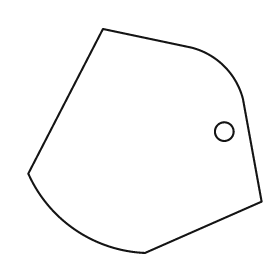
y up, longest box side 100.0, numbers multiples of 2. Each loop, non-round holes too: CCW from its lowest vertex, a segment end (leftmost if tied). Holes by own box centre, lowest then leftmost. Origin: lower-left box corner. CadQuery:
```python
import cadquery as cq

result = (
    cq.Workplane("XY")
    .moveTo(50.0, 0.0)
    .lineTo(100.0, 22.0)
    .lineTo(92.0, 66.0)
    .threePointArc((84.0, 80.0), (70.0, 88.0))
    .lineTo(32.0, 96.0)
    .lineTo(0.0, 34.0)
    .threePointArc((20.0, 10.0), (50.0, 0.0))
    .close()
    .moveTo(84.0, 52.0)
    .circle(4.0)
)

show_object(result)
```